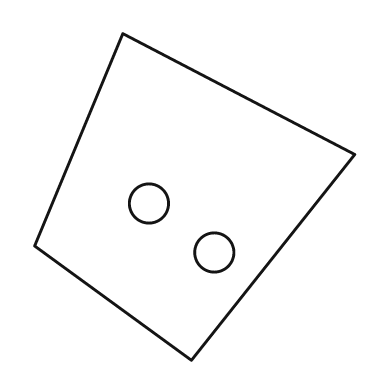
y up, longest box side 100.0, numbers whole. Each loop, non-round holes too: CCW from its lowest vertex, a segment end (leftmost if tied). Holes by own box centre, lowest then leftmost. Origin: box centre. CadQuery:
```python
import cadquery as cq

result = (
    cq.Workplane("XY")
    .moveTo(-1.0, -50.0)
    .lineTo(49.0, 13.0)
    .lineTo(-22.0, 50.0)
    .lineTo(-49.0, -15.0)
    .close()
    .moveTo(6.0, -17.0)
    .circle(6.0)
    .moveTo(-14.0, -2.0)
    .circle(6.0)
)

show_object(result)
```